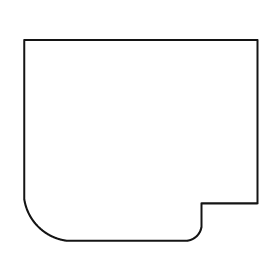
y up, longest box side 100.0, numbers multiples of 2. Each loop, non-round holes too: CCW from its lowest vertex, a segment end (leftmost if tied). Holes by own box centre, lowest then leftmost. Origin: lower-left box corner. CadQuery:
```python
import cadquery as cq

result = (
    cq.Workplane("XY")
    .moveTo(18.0, 0.0)
    .lineTo(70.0, 0.0)
    .threePointArc((74.0, 2.0), (76.0, 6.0))
    .lineTo(76.0, 16.0)
    .lineTo(100.0, 16.0)
    .lineTo(100.0, 86.0)
    .lineTo(0.0, 86.0)
    .lineTo(0.0, 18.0)
    .threePointArc((6.0, 6.0), (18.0, 0.0))
    .close()
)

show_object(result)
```